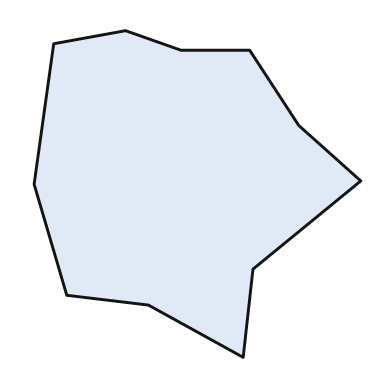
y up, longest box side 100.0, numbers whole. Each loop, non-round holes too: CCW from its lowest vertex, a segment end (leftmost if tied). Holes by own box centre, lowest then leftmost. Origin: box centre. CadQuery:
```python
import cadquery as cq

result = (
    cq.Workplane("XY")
    .moveTo(14.0, -50.0)
    .lineTo(17.0, -23.0)
    .lineTo(50.0, 4.0)
    .lineTo(31.0, 21.0)
    .lineTo(16.0, 44.0)
    .lineTo(-5.0, 44.0)
    .lineTo(-22.0, 50.0)
    .lineTo(-44.0, 46.0)
    .lineTo(-50.0, 3.0)
    .lineTo(-40.0, -31.0)
    .lineTo(-15.0, -34.0)
    .close()
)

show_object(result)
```